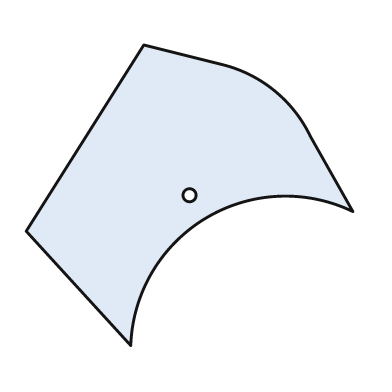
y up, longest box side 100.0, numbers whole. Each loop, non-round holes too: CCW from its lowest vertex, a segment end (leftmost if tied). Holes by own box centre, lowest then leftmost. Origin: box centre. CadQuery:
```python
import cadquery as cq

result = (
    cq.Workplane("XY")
    .moveTo(-18.0, -46.0)
    .threePointArc((5.0, -7.0), (50.0, -5.0))
    .lineTo(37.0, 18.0)
    .threePointArc((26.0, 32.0), (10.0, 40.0))
    .lineTo(-14.0, 46.0)
    .lineTo(-50.0, -11.0)
    .close()
    .moveTo(0.0, 0.0)
    .circle(2.0)
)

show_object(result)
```